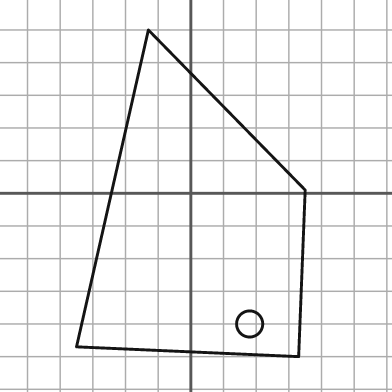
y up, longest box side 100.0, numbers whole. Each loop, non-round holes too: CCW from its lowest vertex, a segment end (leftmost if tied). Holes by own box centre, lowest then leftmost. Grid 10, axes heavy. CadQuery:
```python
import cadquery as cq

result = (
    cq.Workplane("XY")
    .moveTo(33.0, -50.0)
    .lineTo(35.0, 1.0)
    .lineTo(-13.0, 50.0)
    .lineTo(-35.0, -47.0)
    .close()
    .moveTo(18.0, -40.0)
    .circle(4.0)
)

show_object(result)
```